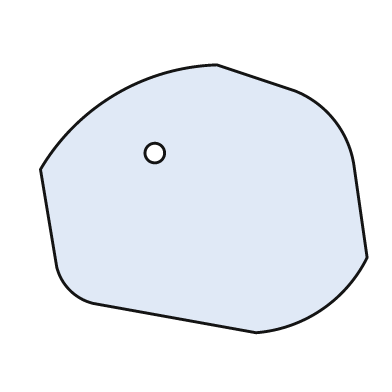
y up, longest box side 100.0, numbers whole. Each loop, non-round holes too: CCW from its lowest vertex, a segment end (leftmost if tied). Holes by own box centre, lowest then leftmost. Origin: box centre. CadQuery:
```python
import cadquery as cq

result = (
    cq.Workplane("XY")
    .moveTo(16.0, -41.0)
    .threePointArc((36.0, -34.0), (50.0, -18.0))
    .lineTo(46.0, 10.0)
    .threePointArc((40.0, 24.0), (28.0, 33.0))
    .lineTo(4.0, 41.0)
    .threePointArc((-27.0, 32.0), (-50.0, 9.0))
    .lineTo(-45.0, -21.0)
    .threePointArc((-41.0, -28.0), (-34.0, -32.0))
    .close()
    .moveTo(-15.0, 14.0)
    .circle(3.0)
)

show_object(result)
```